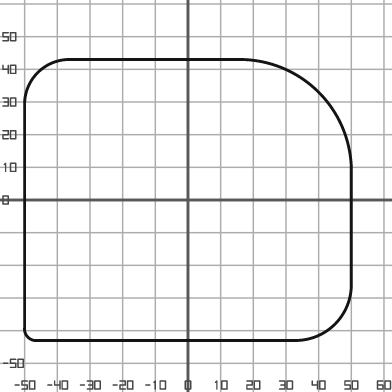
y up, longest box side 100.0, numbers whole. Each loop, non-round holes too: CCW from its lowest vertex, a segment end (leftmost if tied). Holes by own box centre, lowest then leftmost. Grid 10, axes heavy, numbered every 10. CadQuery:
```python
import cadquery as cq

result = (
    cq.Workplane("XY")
    .moveTo(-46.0, -43.0)
    .lineTo(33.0, -43.0)
    .threePointArc((45.0, -38.0), (50.0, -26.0))
    .lineTo(50.0, 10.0)
    .threePointArc((40.0, 33.0), (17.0, 43.0))
    .lineTo(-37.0, 43.0)
    .threePointArc((-46.0, 39.0), (-50.0, 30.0))
    .lineTo(-50.0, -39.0)
    .threePointArc((-49.0, -42.0), (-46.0, -43.0))
    .close()
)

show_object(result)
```